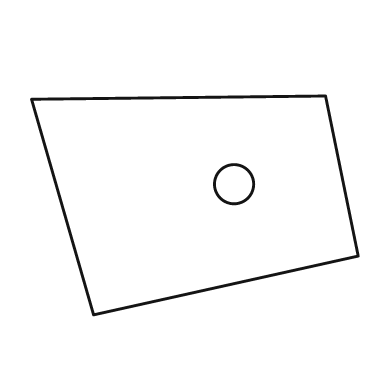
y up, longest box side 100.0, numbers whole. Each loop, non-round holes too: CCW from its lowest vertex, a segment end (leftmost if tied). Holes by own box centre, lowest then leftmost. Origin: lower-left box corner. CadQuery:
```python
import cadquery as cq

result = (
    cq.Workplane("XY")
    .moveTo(19.0, 0.0)
    .lineTo(100.0, 18.0)
    .lineTo(90.0, 67.0)
    .lineTo(0.0, 66.0)
    .close()
    .moveTo(62.0, 40.0)
    .circle(6.0)
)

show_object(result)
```